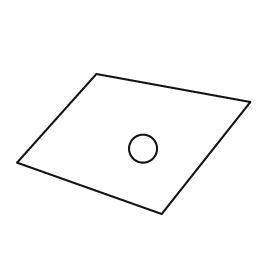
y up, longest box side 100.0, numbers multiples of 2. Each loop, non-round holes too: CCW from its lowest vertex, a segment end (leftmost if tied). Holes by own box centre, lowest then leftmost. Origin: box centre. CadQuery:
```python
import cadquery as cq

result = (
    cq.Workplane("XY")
    .moveTo(12.0, -30.0)
    .lineTo(50.0, 18.0)
    .lineTo(-16.0, 30.0)
    .lineTo(-50.0, -8.0)
    .close()
    .moveTo(4.0, -2.0)
    .circle(6.0)
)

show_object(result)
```